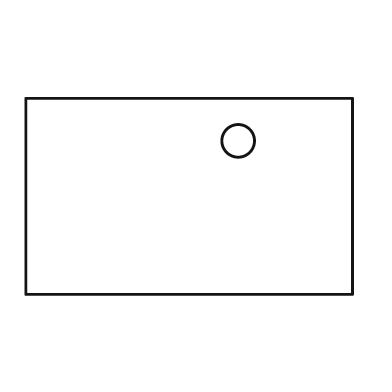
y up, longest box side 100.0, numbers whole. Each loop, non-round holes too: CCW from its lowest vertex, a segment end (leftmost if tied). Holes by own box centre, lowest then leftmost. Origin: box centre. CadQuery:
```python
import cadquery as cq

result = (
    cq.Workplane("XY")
    .moveTo(-50.0, -30.0)
    .lineTo(50.0, -30.0)
    .lineTo(50.0, 30.0)
    .lineTo(-50.0, 30.0)
    .close()
    .moveTo(15.0, 17.0)
    .circle(5.0)
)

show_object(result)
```